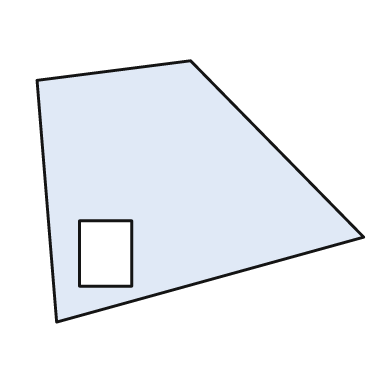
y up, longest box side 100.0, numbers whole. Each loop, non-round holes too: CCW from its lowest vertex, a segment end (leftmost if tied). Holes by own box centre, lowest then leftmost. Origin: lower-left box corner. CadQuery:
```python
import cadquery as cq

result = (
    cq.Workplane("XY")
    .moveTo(6.0, 0.0)
    .lineTo(100.0, 26.0)
    .lineTo(47.0, 80.0)
    .lineTo(0.0, 74.0)
    .close()
    .moveTo(13.0, 11.0)
    .lineTo(29.0, 11.0)
    .lineTo(29.0, 31.0)
    .lineTo(13.0, 31.0)
    .close()
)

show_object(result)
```